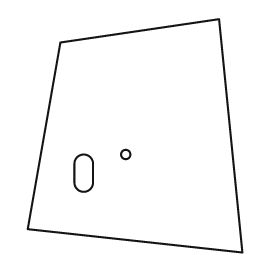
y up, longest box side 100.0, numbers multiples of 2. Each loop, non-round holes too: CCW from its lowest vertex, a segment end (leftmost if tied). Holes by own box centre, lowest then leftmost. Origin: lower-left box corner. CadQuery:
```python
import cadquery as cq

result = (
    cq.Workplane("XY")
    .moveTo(92.0, 0.0)
    .lineTo(82.0, 100.0)
    .lineTo(14.0, 90.0)
    .lineTo(0.0, 10.0)
    .close()
    .moveTo(20.0, 30.0)
    .threePointArc((24.0, 26.0), (28.0, 30.0))
    .lineTo(28.0, 38.0)
    .threePointArc((24.0, 42.0), (20.0, 38.0))
    .close()
    .moveTo(42.0, 42.0)
    .circle(2.0)
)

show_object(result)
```